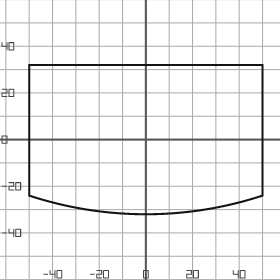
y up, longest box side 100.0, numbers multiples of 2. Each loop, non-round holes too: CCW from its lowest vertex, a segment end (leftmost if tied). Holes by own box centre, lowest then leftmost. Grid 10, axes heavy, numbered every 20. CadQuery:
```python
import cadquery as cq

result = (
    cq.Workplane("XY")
    .moveTo(-50.0, -24.0)
    .threePointArc((0.0, -32.0), (50.0, -24.0))
    .lineTo(50.0, 32.0)
    .lineTo(-50.0, 32.0)
    .close()
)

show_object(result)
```